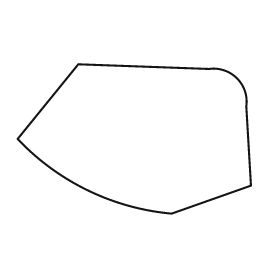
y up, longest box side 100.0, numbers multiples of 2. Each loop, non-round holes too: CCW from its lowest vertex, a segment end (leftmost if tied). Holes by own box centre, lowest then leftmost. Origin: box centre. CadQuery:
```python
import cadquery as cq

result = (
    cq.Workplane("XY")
    .moveTo(16.0, -32.0)
    .lineTo(50.0, -20.0)
    .lineTo(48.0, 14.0)
    .threePointArc((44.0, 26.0), (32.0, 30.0))
    .lineTo(-24.0, 32.0)
    .lineTo(-50.0, 0.0)
    .threePointArc((-20.0, -22.0), (16.0, -32.0))
    .close()
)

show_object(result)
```